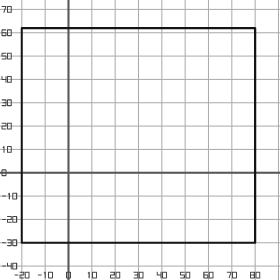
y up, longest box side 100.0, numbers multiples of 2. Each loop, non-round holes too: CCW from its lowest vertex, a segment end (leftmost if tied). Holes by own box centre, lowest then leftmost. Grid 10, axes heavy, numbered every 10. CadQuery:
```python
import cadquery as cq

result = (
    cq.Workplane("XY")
    .moveTo(-20.0, -30.0)
    .lineTo(80.0, -30.0)
    .lineTo(80.0, 62.0)
    .lineTo(-20.0, 62.0)
    .close()
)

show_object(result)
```